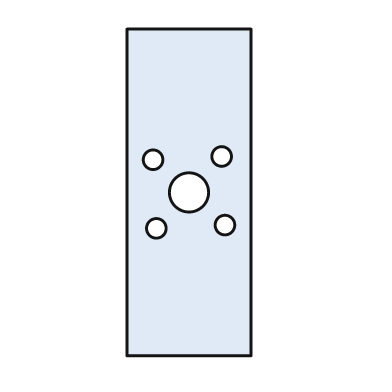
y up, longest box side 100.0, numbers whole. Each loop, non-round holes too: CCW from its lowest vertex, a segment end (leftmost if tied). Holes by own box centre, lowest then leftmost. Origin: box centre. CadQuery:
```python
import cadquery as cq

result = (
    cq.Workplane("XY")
    .moveTo(-19.0, -50.0)
    .lineTo(19.0, -50.0)
    .lineTo(19.0, 50.0)
    .lineTo(-19.0, 50.0)
    .close()
    .moveTo(-10.0, -11.0)
    .circle(3.0)
    .moveTo(11.0, -10.0)
    .circle(3.0)
    .moveTo(0.0, 0.0)
    .circle(6.0)
    .moveTo(-11.0, 10.0)
    .circle(3.0)
    .moveTo(10.0, 11.0)
    .circle(3.0)
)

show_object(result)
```